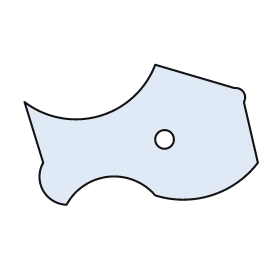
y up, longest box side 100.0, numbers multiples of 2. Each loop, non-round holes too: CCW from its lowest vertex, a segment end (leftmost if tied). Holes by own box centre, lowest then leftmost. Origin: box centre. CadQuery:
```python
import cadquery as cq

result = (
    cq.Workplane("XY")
    .moveTo(-32.0, -30.0)
    .threePointArc((-14.0, -18.0), (6.0, -26.0))
    .threePointArc((30.0, -26.0), (50.0, -12.0))
    .lineTo(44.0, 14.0)
    .threePointArc((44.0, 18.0), (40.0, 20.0))
    .lineTo(6.0, 30.0)
    .threePointArc((-18.0, 8.0), (-50.0, 14.0))
    .lineTo(-42.0, -12.0)
    .threePointArc((-42.0, -24.0), (-32.0, -30.0))
    .close()
    .moveTo(10.0, -2.0)
    .circle(4.0)
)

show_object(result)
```